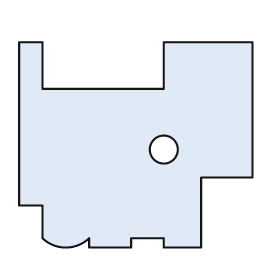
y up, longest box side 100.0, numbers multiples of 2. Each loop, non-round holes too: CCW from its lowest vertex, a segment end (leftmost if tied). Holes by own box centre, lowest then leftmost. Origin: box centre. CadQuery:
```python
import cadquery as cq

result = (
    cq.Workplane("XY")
    .moveTo(-20.0, -44.0)
    .lineTo(-2.0, -44.0)
    .lineTo(-2.0, -40.0)
    .lineTo(12.0, -40.0)
    .lineTo(12.0, -44.0)
    .lineTo(28.0, -44.0)
    .lineTo(28.0, -14.0)
    .lineTo(50.0, -14.0)
    .lineTo(50.0, 44.0)
    .lineTo(12.0, 44.0)
    .lineTo(12.0, 24.0)
    .lineTo(-40.0, 24.0)
    .lineTo(-40.0, 44.0)
    .lineTo(-50.0, 44.0)
    .lineTo(-50.0, -26.0)
    .lineTo(-40.0, -26.0)
    .lineTo(-40.0, -40.0)
    .threePointArc((-30.0, -44.0), (-20.0, -40.0))
    .close()
    .moveTo(12.0, -2.0)
    .circle(6.0)
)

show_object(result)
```